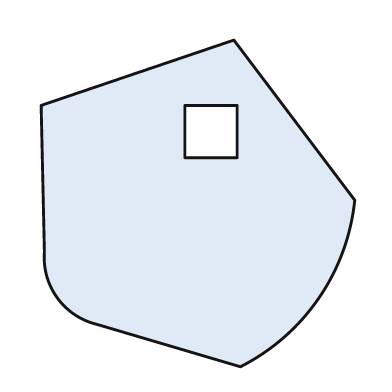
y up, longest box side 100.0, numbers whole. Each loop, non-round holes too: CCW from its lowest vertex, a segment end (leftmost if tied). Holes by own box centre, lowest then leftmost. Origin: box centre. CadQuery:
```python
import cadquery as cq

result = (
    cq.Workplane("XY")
    .moveTo(13.0, -50.0)
    .threePointArc((37.0, -29.0), (48.0, 1.0))
    .lineTo(11.0, 50.0)
    .lineTo(-48.0, 30.0)
    .lineTo(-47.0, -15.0)
    .threePointArc((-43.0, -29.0), (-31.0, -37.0))
    .close()
    .moveTo(-4.0, 14.0)
    .lineTo(12.0, 14.0)
    .lineTo(12.0, 30.0)
    .lineTo(-4.0, 30.0)
    .close()
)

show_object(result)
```